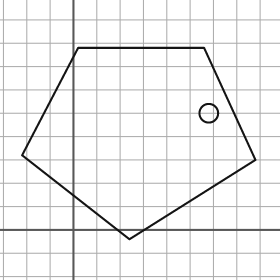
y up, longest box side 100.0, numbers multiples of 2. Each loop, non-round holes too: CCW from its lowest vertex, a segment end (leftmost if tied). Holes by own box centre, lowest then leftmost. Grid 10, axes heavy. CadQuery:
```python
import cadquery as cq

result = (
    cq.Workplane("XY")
    .moveTo(24.0, -4.0)
    .lineTo(78.0, 30.0)
    .lineTo(56.0, 78.0)
    .lineTo(2.0, 78.0)
    .lineTo(-22.0, 32.0)
    .close()
    .moveTo(58.0, 50.0)
    .circle(4.0)
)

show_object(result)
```